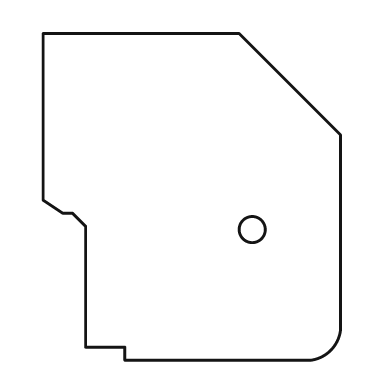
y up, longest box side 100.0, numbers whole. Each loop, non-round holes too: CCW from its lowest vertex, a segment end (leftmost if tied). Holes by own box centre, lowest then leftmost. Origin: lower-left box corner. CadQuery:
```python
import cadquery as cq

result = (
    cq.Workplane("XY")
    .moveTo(25.0, 0.0)
    .lineTo(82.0, 0.0)
    .threePointArc((88.0, 3.0), (91.0, 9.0))
    .lineTo(91.0, 69.0)
    .lineTo(60.0, 100.0)
    .lineTo(0.0, 100.0)
    .lineTo(0.0, 49.0)
    .lineTo(6.0, 45.0)
    .lineTo(9.0, 45.0)
    .lineTo(13.0, 41.0)
    .lineTo(13.0, 4.0)
    .lineTo(25.0, 4.0)
    .close()
    .moveTo(64.0, 40.0)
    .circle(4.0)
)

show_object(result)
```